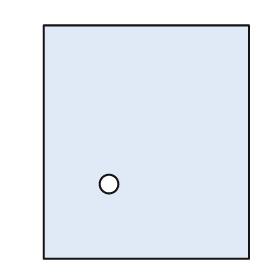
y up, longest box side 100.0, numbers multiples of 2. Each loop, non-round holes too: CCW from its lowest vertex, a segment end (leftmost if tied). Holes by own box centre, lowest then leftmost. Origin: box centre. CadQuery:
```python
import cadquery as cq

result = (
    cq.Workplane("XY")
    .moveTo(-44.0, -50.0)
    .lineTo(44.0, -50.0)
    .lineTo(44.0, 50.0)
    .lineTo(-44.0, 50.0)
    .close()
    .moveTo(-16.0, -18.0)
    .circle(4.0)
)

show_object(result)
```